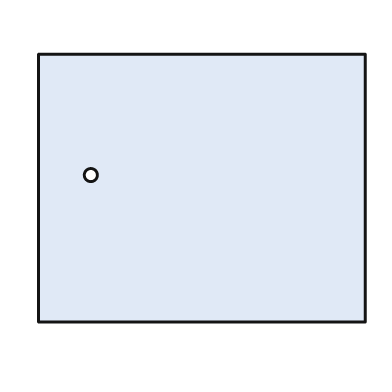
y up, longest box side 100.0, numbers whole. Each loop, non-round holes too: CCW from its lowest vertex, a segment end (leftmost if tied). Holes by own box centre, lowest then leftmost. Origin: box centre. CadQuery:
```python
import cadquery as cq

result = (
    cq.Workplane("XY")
    .moveTo(-50.0, -41.0)
    .lineTo(50.0, -41.0)
    .lineTo(50.0, 41.0)
    .lineTo(-50.0, 41.0)
    .close()
    .moveTo(-34.0, 4.0)
    .circle(2.0)
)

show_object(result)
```